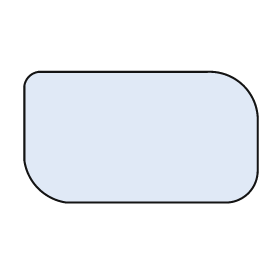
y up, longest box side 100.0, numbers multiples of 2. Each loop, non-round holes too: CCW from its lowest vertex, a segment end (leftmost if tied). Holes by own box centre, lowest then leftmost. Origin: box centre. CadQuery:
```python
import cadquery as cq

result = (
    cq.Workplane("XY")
    .moveTo(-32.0, -28.0)
    .lineTo(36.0, -28.0)
    .threePointArc((46.0, -24.0), (50.0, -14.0))
    .lineTo(50.0, 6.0)
    .threePointArc((44.0, 22.0), (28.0, 28.0))
    .lineTo(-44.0, 28.0)
    .threePointArc((-48.0, 26.0), (-50.0, 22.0))
    .lineTo(-50.0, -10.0)
    .threePointArc((-44.0, -22.0), (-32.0, -28.0))
    .close()
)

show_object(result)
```